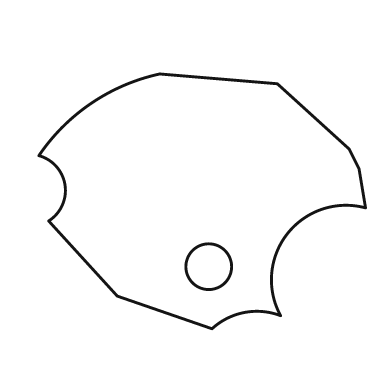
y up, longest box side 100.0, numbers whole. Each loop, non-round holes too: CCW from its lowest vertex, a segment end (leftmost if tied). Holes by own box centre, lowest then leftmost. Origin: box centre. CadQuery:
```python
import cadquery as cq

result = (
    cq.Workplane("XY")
    .moveTo(3.0, -39.0)
    .threePointArc((13.0, -34.0), (24.0, -35.0))
    .threePointArc((26.0, -10.0), (50.0, -2.0))
    .lineTo(48.0, 10.0)
    .lineTo(45.0, 16.0)
    .lineTo(23.0, 36.0)
    .lineTo(-13.0, 39.0)
    .threePointArc((-34.0, 30.0), (-50.0, 14.0))
    .threePointArc((-42.0, 5.0), (-47.0, -6.0))
    .lineTo(-26.0, -29.0)
    .close()
    .moveTo(2.0, -20.0)
    .circle(7.0)
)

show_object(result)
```